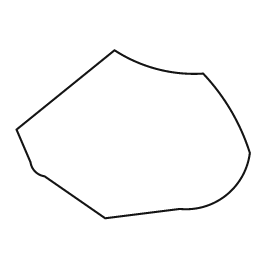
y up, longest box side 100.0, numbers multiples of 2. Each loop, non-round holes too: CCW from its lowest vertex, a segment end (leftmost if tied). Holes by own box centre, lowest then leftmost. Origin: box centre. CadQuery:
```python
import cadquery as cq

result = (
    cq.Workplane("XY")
    .moveTo(-12.0, -36.0)
    .lineTo(20.0, -32.0)
    .threePointArc((40.0, -26.0), (50.0, -8.0))
    .threePointArc((42.0, 10.0), (30.0, 26.0))
    .threePointArc((10.0, 28.0), (-8.0, 36.0))
    .lineTo(-50.0, 2.0)
    .lineTo(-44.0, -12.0)
    .threePointArc((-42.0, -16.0), (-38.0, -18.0))
    .close()
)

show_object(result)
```